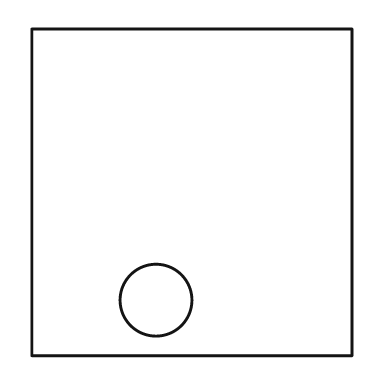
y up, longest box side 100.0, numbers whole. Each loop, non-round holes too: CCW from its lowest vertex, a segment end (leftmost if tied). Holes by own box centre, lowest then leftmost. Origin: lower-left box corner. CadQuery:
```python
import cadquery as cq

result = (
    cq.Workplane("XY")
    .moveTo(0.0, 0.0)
    .lineTo(98.0, 0.0)
    .lineTo(98.0, 100.0)
    .lineTo(0.0, 100.0)
    .close()
    .moveTo(38.0, 17.0)
    .circle(11.0)
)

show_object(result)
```